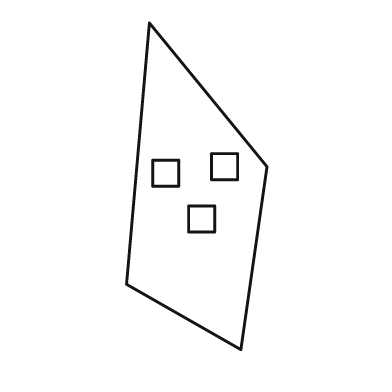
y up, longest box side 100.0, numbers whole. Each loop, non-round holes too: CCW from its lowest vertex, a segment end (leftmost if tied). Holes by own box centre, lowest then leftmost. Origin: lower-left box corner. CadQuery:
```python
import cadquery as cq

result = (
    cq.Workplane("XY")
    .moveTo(35.0, 0.0)
    .lineTo(43.0, 56.0)
    .lineTo(7.0, 100.0)
    .lineTo(0.0, 20.0)
    .close()
    .moveTo(19.0, 36.0)
    .lineTo(27.0, 36.0)
    .lineTo(27.0, 44.0)
    .lineTo(19.0, 44.0)
    .close()
    .moveTo(8.0, 50.0)
    .lineTo(16.0, 50.0)
    .lineTo(16.0, 58.0)
    .lineTo(8.0, 58.0)
    .close()
    .moveTo(26.0, 52.0)
    .lineTo(34.0, 52.0)
    .lineTo(34.0, 60.0)
    .lineTo(26.0, 60.0)
    .close()
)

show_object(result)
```